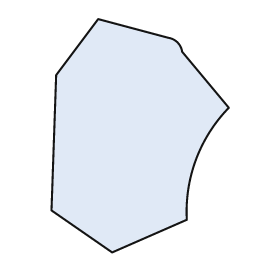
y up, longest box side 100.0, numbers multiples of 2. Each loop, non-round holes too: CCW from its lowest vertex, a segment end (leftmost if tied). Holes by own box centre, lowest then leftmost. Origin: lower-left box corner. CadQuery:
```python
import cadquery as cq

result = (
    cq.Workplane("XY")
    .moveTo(26.0, 0.0)
    .lineTo(58.0, 14.0)
    .threePointArc((62.0, 40.0), (76.0, 62.0))
    .lineTo(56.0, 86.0)
    .threePointArc((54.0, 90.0), (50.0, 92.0))
    .lineTo(20.0, 100.0)
    .lineTo(2.0, 76.0)
    .lineTo(0.0, 18.0)
    .close()
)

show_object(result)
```